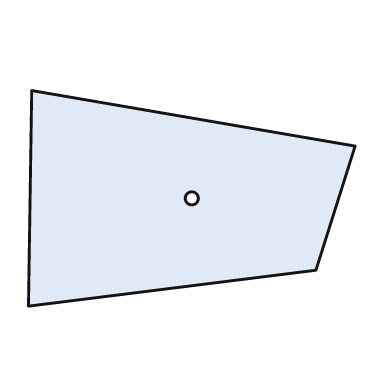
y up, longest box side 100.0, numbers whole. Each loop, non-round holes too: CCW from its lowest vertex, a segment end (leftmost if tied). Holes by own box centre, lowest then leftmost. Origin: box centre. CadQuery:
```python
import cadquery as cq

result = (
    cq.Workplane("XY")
    .moveTo(-50.0, -33.0)
    .lineTo(38.0, -22.0)
    .lineTo(50.0, 16.0)
    .lineTo(-49.0, 33.0)
    .close()
    .moveTo(0.0, 0.0)
    .circle(2.0)
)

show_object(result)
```